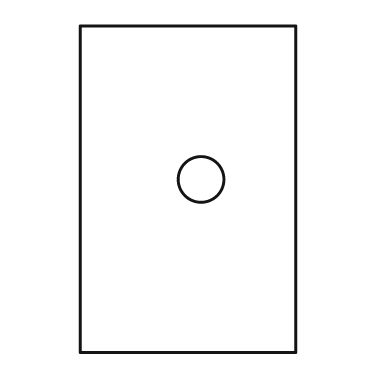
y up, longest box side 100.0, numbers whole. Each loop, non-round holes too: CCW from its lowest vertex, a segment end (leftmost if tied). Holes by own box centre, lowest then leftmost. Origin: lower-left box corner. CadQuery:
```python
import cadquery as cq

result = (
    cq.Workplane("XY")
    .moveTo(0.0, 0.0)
    .lineTo(66.0, 0.0)
    .lineTo(66.0, 100.0)
    .lineTo(0.0, 100.0)
    .close()
    .moveTo(37.0, 53.0)
    .circle(7.0)
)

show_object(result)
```